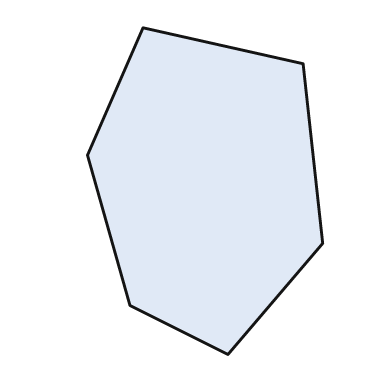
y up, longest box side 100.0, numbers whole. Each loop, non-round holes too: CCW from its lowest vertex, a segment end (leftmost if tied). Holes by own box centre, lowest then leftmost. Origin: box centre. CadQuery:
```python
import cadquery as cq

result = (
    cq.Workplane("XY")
    .moveTo(7.0, -50.0)
    .lineTo(36.0, -16.0)
    .lineTo(30.0, 39.0)
    .lineTo(-19.0, 50.0)
    .lineTo(-36.0, 11.0)
    .lineTo(-23.0, -35.0)
    .close()
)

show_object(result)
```